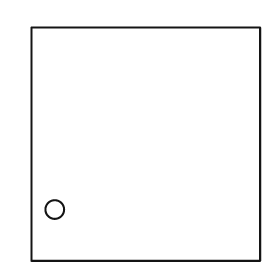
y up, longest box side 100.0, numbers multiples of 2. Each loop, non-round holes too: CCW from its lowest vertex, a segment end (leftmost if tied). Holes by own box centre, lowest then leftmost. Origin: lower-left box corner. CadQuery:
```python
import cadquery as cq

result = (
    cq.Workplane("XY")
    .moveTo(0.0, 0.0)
    .lineTo(98.0, 0.0)
    .lineTo(98.0, 100.0)
    .lineTo(0.0, 100.0)
    .close()
    .moveTo(10.0, 22.0)
    .circle(4.0)
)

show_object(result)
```